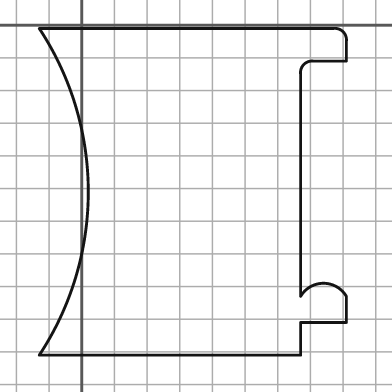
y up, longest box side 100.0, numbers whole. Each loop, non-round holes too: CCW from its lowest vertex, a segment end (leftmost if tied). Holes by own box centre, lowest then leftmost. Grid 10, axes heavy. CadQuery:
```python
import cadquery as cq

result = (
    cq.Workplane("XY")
    .moveTo(-13.0, -101.0)
    .lineTo(67.0, -101.0)
    .lineTo(67.0, -91.0)
    .lineTo(81.0, -91.0)
    .lineTo(81.0, -83.0)
    .threePointArc((74.0, -79.0), (67.0, -83.0))
    .lineTo(67.0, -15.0)
    .threePointArc((68.0, -12.0), (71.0, -11.0))
    .lineTo(81.0, -11.0)
    .lineTo(81.0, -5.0)
    .threePointArc((80.0, -2.0), (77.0, -1.0))
    .lineTo(-13.0, -1.0)
    .threePointArc((2.0, -51.0), (-13.0, -101.0))
    .close()
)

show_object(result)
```